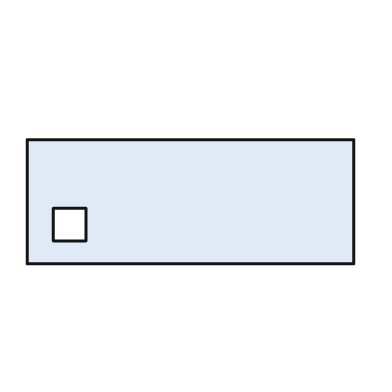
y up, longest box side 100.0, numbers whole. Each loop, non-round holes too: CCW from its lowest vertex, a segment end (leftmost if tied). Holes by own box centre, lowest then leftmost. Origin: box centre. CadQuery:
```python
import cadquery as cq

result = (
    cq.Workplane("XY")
    .moveTo(-50.0, -19.0)
    .lineTo(50.0, -19.0)
    .lineTo(50.0, 19.0)
    .lineTo(-50.0, 19.0)
    .close()
    .moveTo(-42.0, -12.0)
    .lineTo(-32.0, -12.0)
    .lineTo(-32.0, -2.0)
    .lineTo(-42.0, -2.0)
    .close()
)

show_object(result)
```